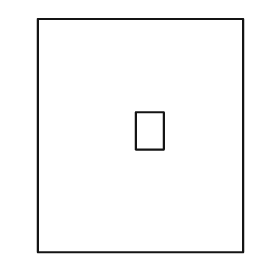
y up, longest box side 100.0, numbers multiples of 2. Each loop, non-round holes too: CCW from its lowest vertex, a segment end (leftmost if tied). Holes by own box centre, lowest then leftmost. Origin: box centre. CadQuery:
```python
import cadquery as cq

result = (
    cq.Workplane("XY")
    .moveTo(-44.0, -50.0)
    .lineTo(44.0, -50.0)
    .lineTo(44.0, 50.0)
    .lineTo(-44.0, 50.0)
    .close()
    .moveTo(-2.0, -6.0)
    .lineTo(10.0, -6.0)
    .lineTo(10.0, 10.0)
    .lineTo(-2.0, 10.0)
    .close()
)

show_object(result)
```